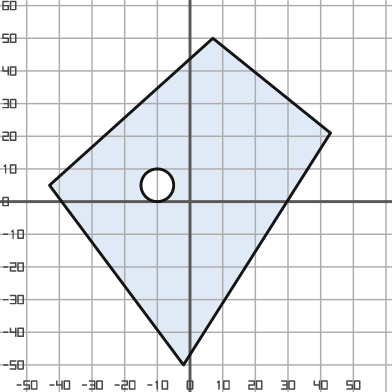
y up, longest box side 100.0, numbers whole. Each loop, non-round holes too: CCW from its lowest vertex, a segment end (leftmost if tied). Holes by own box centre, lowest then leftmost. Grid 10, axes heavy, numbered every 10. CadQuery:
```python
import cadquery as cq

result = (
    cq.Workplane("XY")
    .moveTo(-2.0, -50.0)
    .lineTo(43.0, 21.0)
    .lineTo(7.0, 50.0)
    .lineTo(-43.0, 5.0)
    .close()
    .moveTo(-10.0, 5.0)
    .circle(5.0)
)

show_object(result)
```